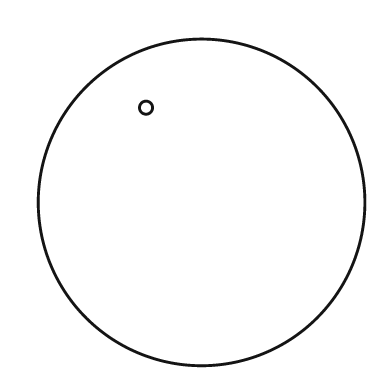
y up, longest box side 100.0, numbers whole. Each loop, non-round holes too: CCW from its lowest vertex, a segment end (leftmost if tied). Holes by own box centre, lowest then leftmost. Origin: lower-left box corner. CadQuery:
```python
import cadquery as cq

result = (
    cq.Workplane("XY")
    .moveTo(50.0, 50.0)
    .circle(50.0)
    .moveTo(33.0, 79.0)
    .circle(2.0)
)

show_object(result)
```